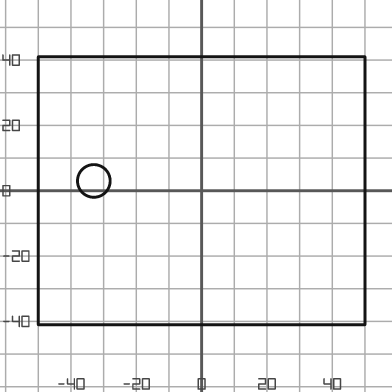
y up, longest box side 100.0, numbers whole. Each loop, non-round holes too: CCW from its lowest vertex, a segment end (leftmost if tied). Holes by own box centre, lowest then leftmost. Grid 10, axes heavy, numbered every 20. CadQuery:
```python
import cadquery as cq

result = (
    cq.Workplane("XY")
    .moveTo(-50.0, -41.0)
    .lineTo(50.0, -41.0)
    .lineTo(50.0, 41.0)
    .lineTo(-50.0, 41.0)
    .close()
    .moveTo(-33.0, 3.0)
    .circle(5.0)
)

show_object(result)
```